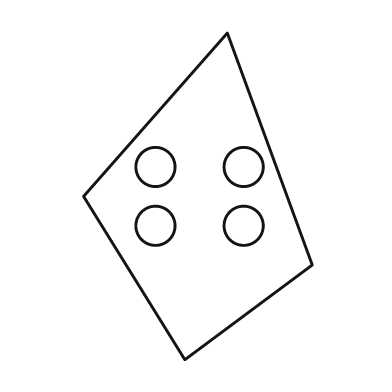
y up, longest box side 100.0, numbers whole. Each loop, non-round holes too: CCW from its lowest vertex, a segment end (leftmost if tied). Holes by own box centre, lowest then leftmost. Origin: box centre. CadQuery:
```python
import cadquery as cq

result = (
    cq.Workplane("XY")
    .moveTo(-4.0, -50.0)
    .lineTo(35.0, -21.0)
    .lineTo(9.0, 50.0)
    .lineTo(-35.0, 0.0)
    .close()
    .moveTo(-13.0, -9.0)
    .circle(6.0)
    .moveTo(14.0, -9.0)
    .circle(6.0)
    .moveTo(-13.0, 9.0)
    .circle(6.0)
    .moveTo(14.0, 9.0)
    .circle(6.0)
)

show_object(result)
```